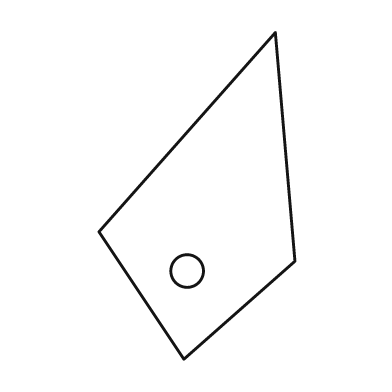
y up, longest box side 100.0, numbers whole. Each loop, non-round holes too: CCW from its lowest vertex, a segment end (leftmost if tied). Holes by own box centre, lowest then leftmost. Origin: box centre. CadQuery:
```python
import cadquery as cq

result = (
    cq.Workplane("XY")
    .moveTo(-4.0, -50.0)
    .lineTo(30.0, -20.0)
    .lineTo(24.0, 50.0)
    .lineTo(-30.0, -11.0)
    .close()
    .moveTo(-3.0, -23.0)
    .circle(5.0)
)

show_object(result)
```